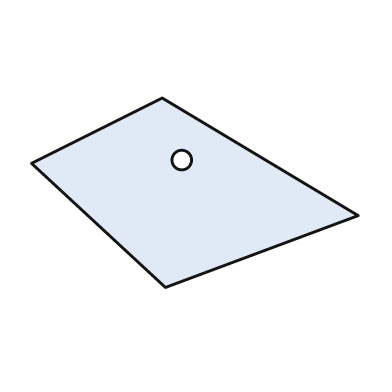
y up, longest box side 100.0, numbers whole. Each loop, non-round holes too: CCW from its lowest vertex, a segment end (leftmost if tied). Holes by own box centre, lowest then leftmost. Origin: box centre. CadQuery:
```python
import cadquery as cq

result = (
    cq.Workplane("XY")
    .moveTo(-9.0, -29.0)
    .lineTo(50.0, -7.0)
    .lineTo(-10.0, 29.0)
    .lineTo(-50.0, 9.0)
    .close()
    .moveTo(-4.0, 10.0)
    .circle(3.0)
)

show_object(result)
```